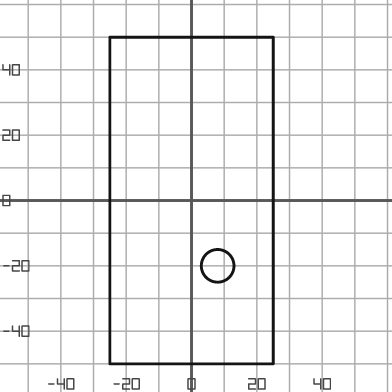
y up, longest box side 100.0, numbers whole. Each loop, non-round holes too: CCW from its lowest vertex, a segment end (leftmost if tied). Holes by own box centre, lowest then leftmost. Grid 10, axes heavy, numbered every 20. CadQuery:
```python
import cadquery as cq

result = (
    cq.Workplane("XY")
    .moveTo(-25.0, -50.0)
    .lineTo(25.0, -50.0)
    .lineTo(25.0, 50.0)
    .lineTo(-25.0, 50.0)
    .close()
    .moveTo(8.0, -20.0)
    .circle(5.0)
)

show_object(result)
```